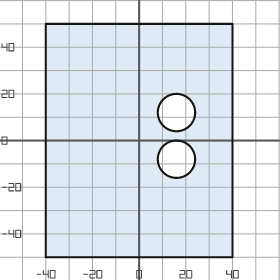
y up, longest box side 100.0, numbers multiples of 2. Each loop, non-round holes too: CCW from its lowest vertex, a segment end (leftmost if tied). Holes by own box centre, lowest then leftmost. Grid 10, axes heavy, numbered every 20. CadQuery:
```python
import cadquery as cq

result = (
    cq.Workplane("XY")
    .moveTo(-40.0, -50.0)
    .lineTo(40.0, -50.0)
    .lineTo(40.0, 50.0)
    .lineTo(-40.0, 50.0)
    .close()
    .moveTo(16.0, -8.0)
    .circle(8.0)
    .moveTo(16.0, 12.0)
    .circle(8.0)
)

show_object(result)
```